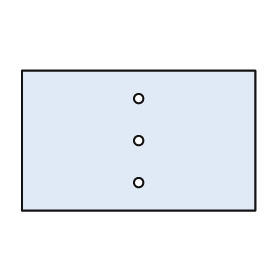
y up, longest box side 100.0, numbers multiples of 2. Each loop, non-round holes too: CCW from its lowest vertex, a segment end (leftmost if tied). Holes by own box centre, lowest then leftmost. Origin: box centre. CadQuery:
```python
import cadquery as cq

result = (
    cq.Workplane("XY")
    .moveTo(-50.0, -30.0)
    .lineTo(50.0, -30.0)
    .lineTo(50.0, 30.0)
    .lineTo(-50.0, 30.0)
    .close()
    .moveTo(0.0, -18.0)
    .circle(2.0)
    .moveTo(0.0, 0.0)
    .circle(2.0)
    .moveTo(0.0, 18.0)
    .circle(2.0)
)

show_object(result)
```